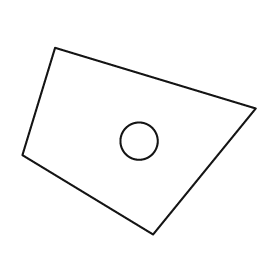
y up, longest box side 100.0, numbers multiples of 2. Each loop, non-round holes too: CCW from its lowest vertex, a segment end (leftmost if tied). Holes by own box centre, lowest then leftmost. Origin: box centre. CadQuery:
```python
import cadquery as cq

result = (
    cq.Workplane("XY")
    .moveTo(6.0, -40.0)
    .lineTo(50.0, 14.0)
    .lineTo(-36.0, 40.0)
    .lineTo(-50.0, -6.0)
    .close()
    .moveTo(0.0, 0.0)
    .circle(8.0)
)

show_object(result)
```